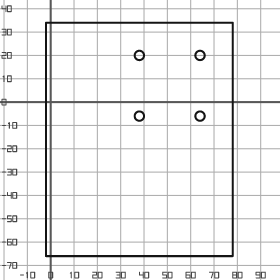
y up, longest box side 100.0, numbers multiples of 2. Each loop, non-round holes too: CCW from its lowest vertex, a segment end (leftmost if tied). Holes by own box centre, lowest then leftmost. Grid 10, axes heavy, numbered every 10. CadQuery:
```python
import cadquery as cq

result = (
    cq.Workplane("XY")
    .moveTo(-2.0, -66.0)
    .lineTo(78.0, -66.0)
    .lineTo(78.0, 34.0)
    .lineTo(-2.0, 34.0)
    .close()
    .moveTo(38.0, -6.0)
    .circle(2.0)
    .moveTo(64.0, -6.0)
    .circle(2.0)
    .moveTo(38.0, 20.0)
    .circle(2.0)
    .moveTo(64.0, 20.0)
    .circle(2.0)
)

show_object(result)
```